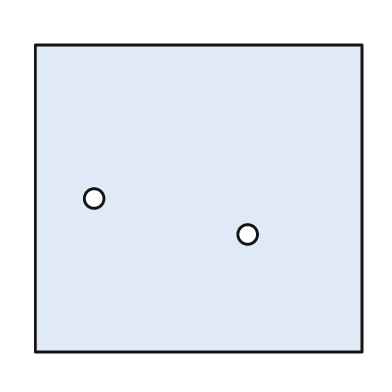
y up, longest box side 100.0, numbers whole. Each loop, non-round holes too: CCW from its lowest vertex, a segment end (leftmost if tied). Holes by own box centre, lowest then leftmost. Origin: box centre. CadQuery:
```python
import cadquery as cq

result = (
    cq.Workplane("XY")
    .moveTo(-50.0, -47.0)
    .lineTo(50.0, -47.0)
    .lineTo(50.0, 47.0)
    .lineTo(-50.0, 47.0)
    .close()
    .moveTo(15.0, -11.0)
    .circle(3.0)
    .moveTo(-32.0, 0.0)
    .circle(3.0)
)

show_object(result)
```